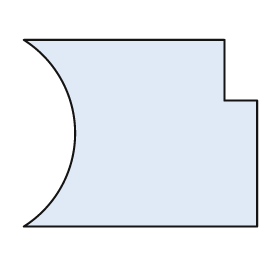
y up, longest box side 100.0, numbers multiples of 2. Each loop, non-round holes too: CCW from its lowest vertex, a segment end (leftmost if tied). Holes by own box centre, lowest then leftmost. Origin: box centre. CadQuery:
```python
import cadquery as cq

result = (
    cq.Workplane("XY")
    .moveTo(-50.0, -40.0)
    .lineTo(50.0, -40.0)
    .lineTo(50.0, 14.0)
    .lineTo(36.0, 14.0)
    .lineTo(36.0, 40.0)
    .lineTo(-50.0, 40.0)
    .threePointArc((-28.0, 0.0), (-50.0, -40.0))
    .close()
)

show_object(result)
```